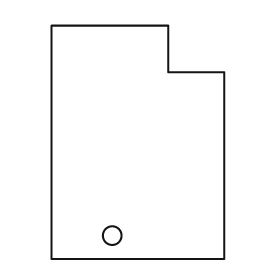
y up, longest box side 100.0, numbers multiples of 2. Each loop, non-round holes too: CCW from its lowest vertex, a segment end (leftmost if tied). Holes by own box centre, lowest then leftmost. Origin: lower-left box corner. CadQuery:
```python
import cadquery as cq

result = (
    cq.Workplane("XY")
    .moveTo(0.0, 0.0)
    .lineTo(74.0, 0.0)
    .lineTo(74.0, 80.0)
    .lineTo(50.0, 80.0)
    .lineTo(50.0, 100.0)
    .lineTo(0.0, 100.0)
    .close()
    .moveTo(26.0, 10.0)
    .circle(4.0)
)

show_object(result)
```